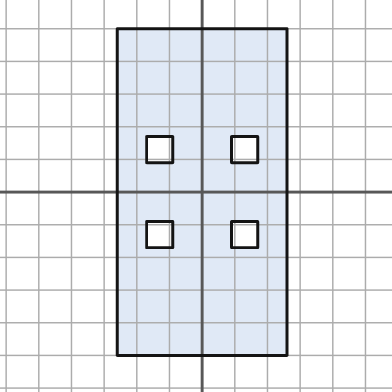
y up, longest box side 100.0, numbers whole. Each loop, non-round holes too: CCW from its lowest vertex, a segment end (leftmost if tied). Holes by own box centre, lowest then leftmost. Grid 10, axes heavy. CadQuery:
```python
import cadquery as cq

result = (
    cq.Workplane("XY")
    .moveTo(-26.0, -50.0)
    .lineTo(26.0, -50.0)
    .lineTo(26.0, 50.0)
    .lineTo(-26.0, 50.0)
    .close()
    .moveTo(-17.0, -17.0)
    .lineTo(-9.0, -17.0)
    .lineTo(-9.0, -9.0)
    .lineTo(-17.0, -9.0)
    .close()
    .moveTo(9.0, -17.0)
    .lineTo(17.0, -17.0)
    .lineTo(17.0, -9.0)
    .lineTo(9.0, -9.0)
    .close()
    .moveTo(-17.0, 9.0)
    .lineTo(-9.0, 9.0)
    .lineTo(-9.0, 17.0)
    .lineTo(-17.0, 17.0)
    .close()
    .moveTo(9.0, 9.0)
    .lineTo(17.0, 9.0)
    .lineTo(17.0, 17.0)
    .lineTo(9.0, 17.0)
    .close()
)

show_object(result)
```